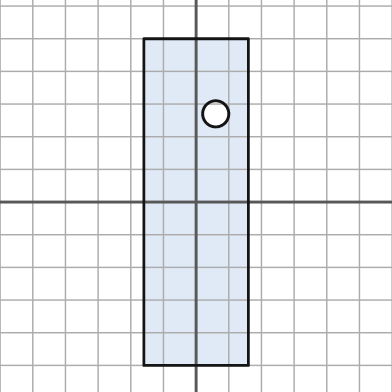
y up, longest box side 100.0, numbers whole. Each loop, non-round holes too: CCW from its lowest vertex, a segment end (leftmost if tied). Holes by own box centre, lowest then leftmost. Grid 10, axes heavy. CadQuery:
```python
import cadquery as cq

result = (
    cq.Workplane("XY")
    .moveTo(-16.0, -50.0)
    .lineTo(16.0, -50.0)
    .lineTo(16.0, 50.0)
    .lineTo(-16.0, 50.0)
    .close()
    .moveTo(6.0, 27.0)
    .circle(4.0)
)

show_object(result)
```